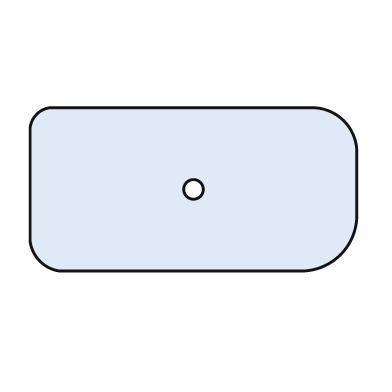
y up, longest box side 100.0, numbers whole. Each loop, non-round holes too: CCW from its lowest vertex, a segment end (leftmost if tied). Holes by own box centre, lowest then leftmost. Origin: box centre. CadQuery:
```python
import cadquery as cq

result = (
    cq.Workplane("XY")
    .moveTo(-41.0, -25.0)
    .lineTo(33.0, -25.0)
    .threePointArc((45.0, -20.0), (50.0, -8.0))
    .lineTo(50.0, 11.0)
    .threePointArc((46.0, 21.0), (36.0, 25.0))
    .lineTo(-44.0, 25.0)
    .threePointArc((-48.0, 23.0), (-50.0, 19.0))
    .lineTo(-50.0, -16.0)
    .threePointArc((-47.0, -22.0), (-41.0, -25.0))
    .close()
    .moveTo(0.0, 0.0)
    .circle(3.0)
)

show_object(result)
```